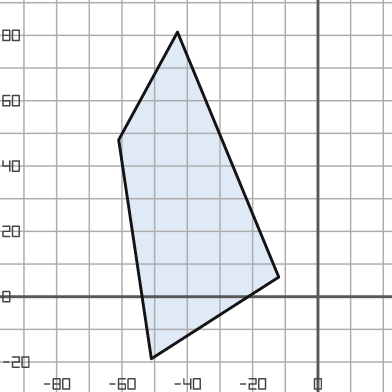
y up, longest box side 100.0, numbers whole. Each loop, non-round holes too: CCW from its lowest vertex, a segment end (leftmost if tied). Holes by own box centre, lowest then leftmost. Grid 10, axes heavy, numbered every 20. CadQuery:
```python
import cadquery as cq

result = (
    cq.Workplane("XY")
    .moveTo(-51.0, -19.0)
    .lineTo(-12.0, 6.0)
    .lineTo(-43.0, 81.0)
    .lineTo(-61.0, 48.0)
    .close()
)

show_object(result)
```